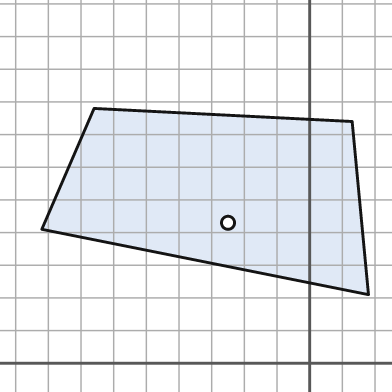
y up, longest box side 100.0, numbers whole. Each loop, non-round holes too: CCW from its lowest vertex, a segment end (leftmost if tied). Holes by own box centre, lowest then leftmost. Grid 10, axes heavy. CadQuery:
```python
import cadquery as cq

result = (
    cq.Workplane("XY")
    .moveTo(18.0, 21.0)
    .lineTo(13.0, 74.0)
    .lineTo(-66.0, 78.0)
    .lineTo(-82.0, 41.0)
    .close()
    .moveTo(-25.0, 43.0)
    .circle(2.0)
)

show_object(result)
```